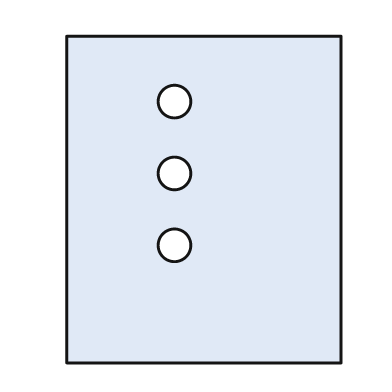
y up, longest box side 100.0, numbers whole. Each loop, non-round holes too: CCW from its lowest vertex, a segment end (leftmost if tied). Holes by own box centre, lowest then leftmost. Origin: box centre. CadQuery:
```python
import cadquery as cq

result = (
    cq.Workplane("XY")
    .moveTo(-42.0, -50.0)
    .lineTo(42.0, -50.0)
    .lineTo(42.0, 50.0)
    .lineTo(-42.0, 50.0)
    .close()
    .moveTo(-9.0, -14.0)
    .circle(5.0)
    .moveTo(-9.0, 8.0)
    .circle(5.0)
    .moveTo(-9.0, 30.0)
    .circle(5.0)
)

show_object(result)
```